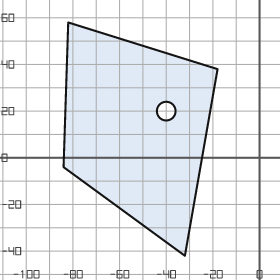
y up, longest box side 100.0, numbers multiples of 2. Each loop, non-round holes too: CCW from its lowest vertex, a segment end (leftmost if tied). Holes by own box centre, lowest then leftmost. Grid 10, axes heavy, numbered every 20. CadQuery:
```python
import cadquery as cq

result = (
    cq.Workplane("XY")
    .moveTo(-32.0, -42.0)
    .lineTo(-18.0, 38.0)
    .lineTo(-82.0, 58.0)
    .lineTo(-84.0, -4.0)
    .close()
    .moveTo(-40.0, 20.0)
    .circle(4.0)
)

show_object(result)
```